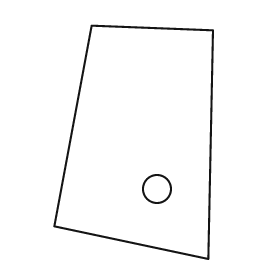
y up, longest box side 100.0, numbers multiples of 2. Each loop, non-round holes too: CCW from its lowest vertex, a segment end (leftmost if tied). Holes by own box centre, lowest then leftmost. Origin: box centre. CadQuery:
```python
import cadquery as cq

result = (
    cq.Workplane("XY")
    .moveTo(32.0, -50.0)
    .lineTo(34.0, 48.0)
    .lineTo(-18.0, 50.0)
    .lineTo(-34.0, -36.0)
    .close()
    .moveTo(10.0, -20.0)
    .circle(6.0)
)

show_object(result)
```